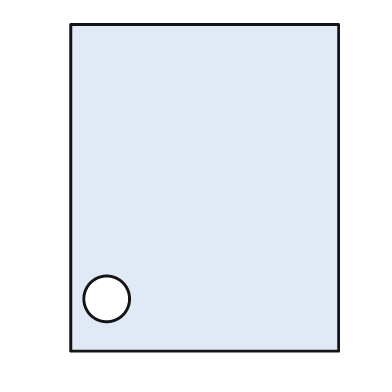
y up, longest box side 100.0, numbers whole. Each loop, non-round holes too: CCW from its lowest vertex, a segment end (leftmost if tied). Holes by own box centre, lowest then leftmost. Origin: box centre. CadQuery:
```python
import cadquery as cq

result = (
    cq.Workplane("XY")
    .moveTo(-41.0, -50.0)
    .lineTo(41.0, -50.0)
    .lineTo(41.0, 50.0)
    .lineTo(-41.0, 50.0)
    .close()
    .moveTo(-30.0, -34.0)
    .circle(7.0)
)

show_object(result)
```